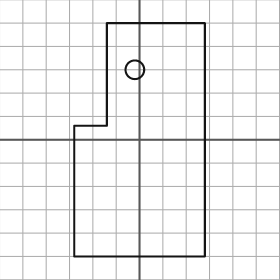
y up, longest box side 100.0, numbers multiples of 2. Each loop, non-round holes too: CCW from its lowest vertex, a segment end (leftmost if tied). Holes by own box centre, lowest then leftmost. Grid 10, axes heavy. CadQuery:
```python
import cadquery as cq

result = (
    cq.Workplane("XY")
    .moveTo(-28.0, -50.0)
    .lineTo(28.0, -50.0)
    .lineTo(28.0, 50.0)
    .lineTo(-14.0, 50.0)
    .lineTo(-14.0, 6.0)
    .lineTo(-28.0, 6.0)
    .close()
    .moveTo(-2.0, 30.0)
    .circle(4.0)
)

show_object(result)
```